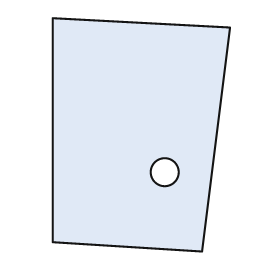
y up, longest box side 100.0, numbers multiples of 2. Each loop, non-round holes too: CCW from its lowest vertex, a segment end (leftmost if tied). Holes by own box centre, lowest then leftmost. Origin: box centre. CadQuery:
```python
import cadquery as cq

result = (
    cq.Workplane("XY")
    .moveTo(26.0, -50.0)
    .lineTo(38.0, 46.0)
    .lineTo(-38.0, 50.0)
    .lineTo(-38.0, -46.0)
    .close()
    .moveTo(10.0, -16.0)
    .circle(6.0)
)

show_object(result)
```